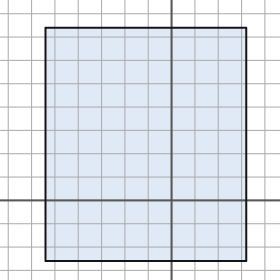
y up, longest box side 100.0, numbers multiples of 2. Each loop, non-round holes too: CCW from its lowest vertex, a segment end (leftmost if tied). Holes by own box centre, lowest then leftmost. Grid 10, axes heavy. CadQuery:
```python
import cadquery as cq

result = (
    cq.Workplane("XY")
    .moveTo(-54.0, -26.0)
    .lineTo(32.0, -26.0)
    .lineTo(32.0, 74.0)
    .lineTo(-54.0, 74.0)
    .close()
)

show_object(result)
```